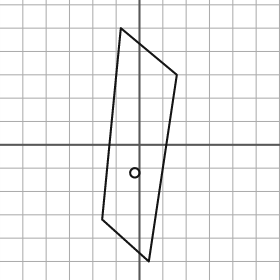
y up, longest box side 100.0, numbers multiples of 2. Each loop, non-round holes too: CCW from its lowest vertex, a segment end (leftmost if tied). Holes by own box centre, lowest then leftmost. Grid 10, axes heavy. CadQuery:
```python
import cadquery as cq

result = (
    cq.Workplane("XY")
    .moveTo(4.0, -50.0)
    .lineTo(16.0, 30.0)
    .lineTo(-8.0, 50.0)
    .lineTo(-16.0, -32.0)
    .close()
    .moveTo(-2.0, -12.0)
    .circle(2.0)
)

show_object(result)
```